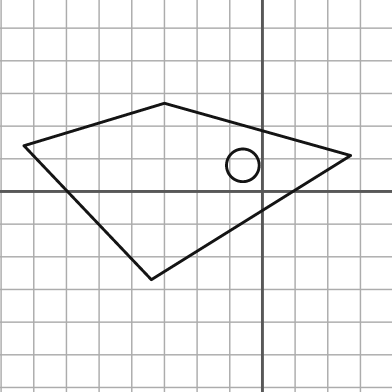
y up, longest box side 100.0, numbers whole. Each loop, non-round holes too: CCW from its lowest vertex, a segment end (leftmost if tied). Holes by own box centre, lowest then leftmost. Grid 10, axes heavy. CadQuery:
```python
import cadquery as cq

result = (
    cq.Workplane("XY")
    .moveTo(-34.0, -27.0)
    .lineTo(27.0, 11.0)
    .lineTo(-30.0, 27.0)
    .lineTo(-73.0, 14.0)
    .close()
    .moveTo(-6.0, 8.0)
    .circle(5.0)
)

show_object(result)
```